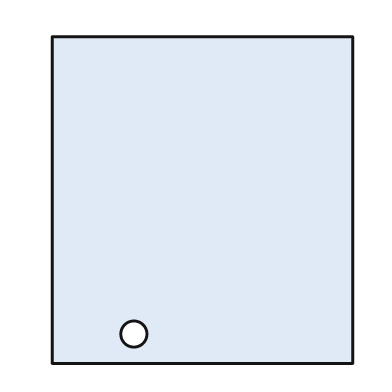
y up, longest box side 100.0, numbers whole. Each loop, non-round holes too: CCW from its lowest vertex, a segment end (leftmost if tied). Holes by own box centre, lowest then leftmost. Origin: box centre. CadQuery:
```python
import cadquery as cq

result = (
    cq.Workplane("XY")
    .moveTo(-46.0, -50.0)
    .lineTo(46.0, -50.0)
    .lineTo(46.0, 50.0)
    .lineTo(-46.0, 50.0)
    .close()
    .moveTo(-21.0, -41.0)
    .circle(4.0)
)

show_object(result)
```